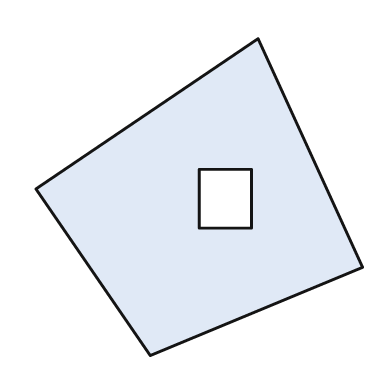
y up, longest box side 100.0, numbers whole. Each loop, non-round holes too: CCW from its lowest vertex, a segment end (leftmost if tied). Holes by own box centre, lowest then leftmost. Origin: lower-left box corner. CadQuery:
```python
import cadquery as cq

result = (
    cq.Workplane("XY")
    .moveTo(35.0, 0.0)
    .lineTo(100.0, 27.0)
    .lineTo(68.0, 97.0)
    .lineTo(0.0, 51.0)
    .close()
    .moveTo(50.0, 39.0)
    .lineTo(66.0, 39.0)
    .lineTo(66.0, 57.0)
    .lineTo(50.0, 57.0)
    .close()
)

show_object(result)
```